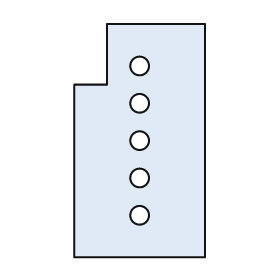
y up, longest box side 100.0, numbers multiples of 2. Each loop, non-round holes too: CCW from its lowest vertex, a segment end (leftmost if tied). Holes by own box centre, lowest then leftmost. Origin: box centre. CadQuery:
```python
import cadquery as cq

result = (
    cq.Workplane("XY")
    .moveTo(-28.0, -50.0)
    .lineTo(28.0, -50.0)
    .lineTo(28.0, 50.0)
    .lineTo(-14.0, 50.0)
    .lineTo(-14.0, 24.0)
    .lineTo(-28.0, 24.0)
    .close()
    .moveTo(0.0, -32.0)
    .circle(4.0)
    .moveTo(0.0, -16.0)
    .circle(4.0)
    .moveTo(0.0, 0.0)
    .circle(4.0)
    .moveTo(0.0, 16.0)
    .circle(4.0)
    .moveTo(0.0, 32.0)
    .circle(4.0)
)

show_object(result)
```